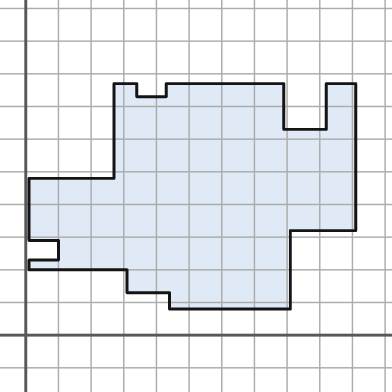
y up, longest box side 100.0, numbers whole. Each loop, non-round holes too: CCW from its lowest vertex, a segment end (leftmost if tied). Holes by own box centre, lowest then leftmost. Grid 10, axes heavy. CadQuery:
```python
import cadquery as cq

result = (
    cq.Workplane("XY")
    .moveTo(44.0, 8.0)
    .lineTo(81.0, 8.0)
    .lineTo(81.0, 32.0)
    .lineTo(101.0, 32.0)
    .lineTo(101.0, 77.0)
    .lineTo(92.0, 77.0)
    .lineTo(92.0, 63.0)
    .lineTo(79.0, 63.0)
    .lineTo(79.0, 77.0)
    .lineTo(43.0, 77.0)
    .lineTo(43.0, 73.0)
    .lineTo(34.0, 73.0)
    .lineTo(34.0, 77.0)
    .lineTo(27.0, 77.0)
    .lineTo(27.0, 48.0)
    .lineTo(1.0, 48.0)
    .lineTo(1.0, 29.0)
    .lineTo(10.0, 29.0)
    .lineTo(10.0, 23.0)
    .lineTo(1.0, 23.0)
    .lineTo(1.0, 20.0)
    .lineTo(31.0, 20.0)
    .lineTo(31.0, 13.0)
    .lineTo(44.0, 13.0)
    .close()
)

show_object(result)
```